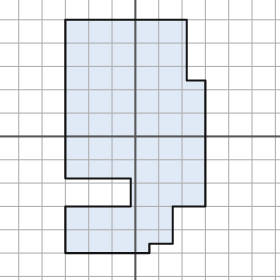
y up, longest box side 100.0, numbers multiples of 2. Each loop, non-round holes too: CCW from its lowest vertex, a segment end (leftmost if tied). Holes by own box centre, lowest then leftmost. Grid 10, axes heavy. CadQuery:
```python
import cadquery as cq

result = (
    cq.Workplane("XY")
    .moveTo(-30.0, -50.0)
    .lineTo(6.0, -50.0)
    .lineTo(6.0, -46.0)
    .lineTo(16.0, -46.0)
    .lineTo(16.0, -30.0)
    .lineTo(30.0, -30.0)
    .lineTo(30.0, 24.0)
    .lineTo(22.0, 24.0)
    .lineTo(22.0, 50.0)
    .lineTo(-30.0, 50.0)
    .lineTo(-30.0, -18.0)
    .lineTo(-2.0, -18.0)
    .lineTo(-2.0, -30.0)
    .lineTo(-30.0, -30.0)
    .close()
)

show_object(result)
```